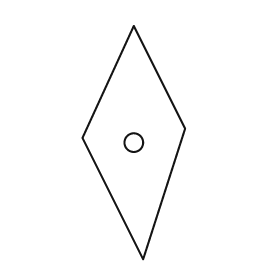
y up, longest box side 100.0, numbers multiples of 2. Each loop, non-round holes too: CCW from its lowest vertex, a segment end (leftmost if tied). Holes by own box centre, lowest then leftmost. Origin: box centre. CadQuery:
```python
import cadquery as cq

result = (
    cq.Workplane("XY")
    .moveTo(4.0, -50.0)
    .lineTo(22.0, 6.0)
    .lineTo(0.0, 50.0)
    .lineTo(-22.0, 2.0)
    .close()
    .moveTo(0.0, 0.0)
    .circle(4.0)
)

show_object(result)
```